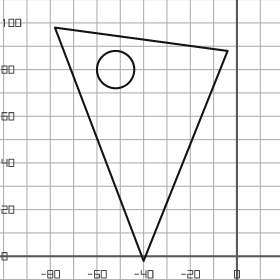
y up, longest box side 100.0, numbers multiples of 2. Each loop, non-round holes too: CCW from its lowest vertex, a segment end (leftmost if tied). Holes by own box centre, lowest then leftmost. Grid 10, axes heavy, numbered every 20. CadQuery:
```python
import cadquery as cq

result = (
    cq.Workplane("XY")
    .moveTo(-40.0, -2.0)
    .lineTo(-4.0, 88.0)
    .lineTo(-78.0, 98.0)
    .close()
    .moveTo(-52.0, 80.0)
    .circle(8.0)
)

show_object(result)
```